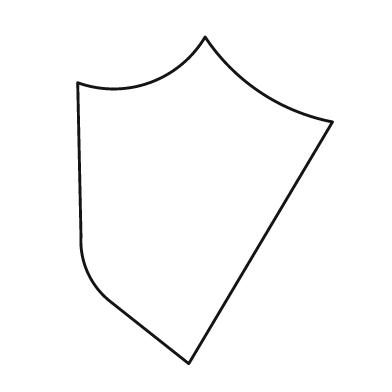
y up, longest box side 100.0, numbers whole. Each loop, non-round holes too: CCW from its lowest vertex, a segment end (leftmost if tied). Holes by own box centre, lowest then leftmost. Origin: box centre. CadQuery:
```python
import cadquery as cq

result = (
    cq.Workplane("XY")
    .moveTo(-5.0, -50.0)
    .lineTo(39.0, 24.0)
    .threePointArc((17.0, 33.0), (0.0, 50.0))
    .threePointArc((-17.0, 36.0), (-39.0, 36.0))
    .lineTo(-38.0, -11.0)
    .threePointArc((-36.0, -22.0), (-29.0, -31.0))
    .close()
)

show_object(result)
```